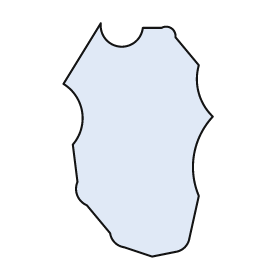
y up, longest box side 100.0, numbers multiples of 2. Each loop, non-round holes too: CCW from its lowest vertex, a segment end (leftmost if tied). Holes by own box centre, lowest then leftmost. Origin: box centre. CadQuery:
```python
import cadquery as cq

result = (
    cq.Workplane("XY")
    .moveTo(6.0, -50.0)
    .lineTo(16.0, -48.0)
    .threePointArc((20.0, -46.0), (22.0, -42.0))
    .lineTo(26.0, -24.0)
    .threePointArc((24.0, -6.0), (32.0, 10.0))
    .threePointArc((26.0, 20.0), (26.0, 32.0))
    .lineTo(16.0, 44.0)
    .threePointArc((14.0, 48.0), (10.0, 48.0))
    .lineTo(2.0, 48.0)
    .threePointArc((-8.0, 40.0), (-16.0, 50.0))
    .lineTo(-32.0, 24.0)
    .threePointArc((-24.0, 12.0), (-28.0, -2.0))
    .lineTo(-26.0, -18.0)
    .threePointArc((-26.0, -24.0), (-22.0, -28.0))
    .lineTo(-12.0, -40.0)
    .threePointArc((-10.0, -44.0), (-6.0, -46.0))
    .close()
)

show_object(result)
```